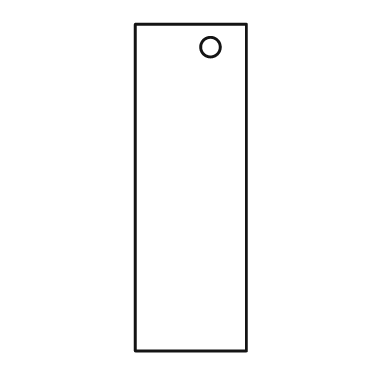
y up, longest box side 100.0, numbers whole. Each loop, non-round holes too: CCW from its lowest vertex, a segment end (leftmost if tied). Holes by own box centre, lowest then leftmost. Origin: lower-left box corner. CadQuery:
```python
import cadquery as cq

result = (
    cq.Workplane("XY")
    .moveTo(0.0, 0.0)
    .lineTo(34.0, 0.0)
    .lineTo(34.0, 100.0)
    .lineTo(0.0, 100.0)
    .close()
    .moveTo(23.0, 93.0)
    .circle(3.0)
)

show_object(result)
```